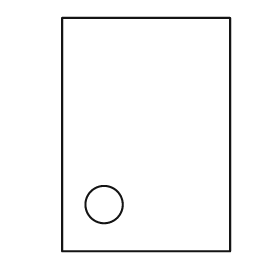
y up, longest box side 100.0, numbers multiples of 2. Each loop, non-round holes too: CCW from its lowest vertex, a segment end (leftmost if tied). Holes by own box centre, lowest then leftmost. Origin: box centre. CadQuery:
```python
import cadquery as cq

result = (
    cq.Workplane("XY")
    .moveTo(-36.0, -50.0)
    .lineTo(36.0, -50.0)
    .lineTo(36.0, 50.0)
    .lineTo(-36.0, 50.0)
    .close()
    .moveTo(-18.0, -30.0)
    .circle(8.0)
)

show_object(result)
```